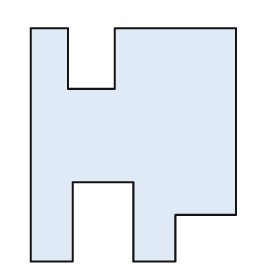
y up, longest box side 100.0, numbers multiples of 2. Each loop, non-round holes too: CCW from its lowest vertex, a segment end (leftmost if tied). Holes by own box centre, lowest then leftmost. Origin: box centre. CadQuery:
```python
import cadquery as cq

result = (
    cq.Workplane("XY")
    .moveTo(-44.0, -50.0)
    .lineTo(-26.0, -50.0)
    .lineTo(-26.0, -16.0)
    .lineTo(0.0, -16.0)
    .lineTo(0.0, -50.0)
    .lineTo(18.0, -50.0)
    .lineTo(18.0, -30.0)
    .lineTo(44.0, -30.0)
    .lineTo(44.0, 50.0)
    .lineTo(-8.0, 50.0)
    .lineTo(-8.0, 24.0)
    .lineTo(-28.0, 24.0)
    .lineTo(-28.0, 50.0)
    .lineTo(-44.0, 50.0)
    .close()
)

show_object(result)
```